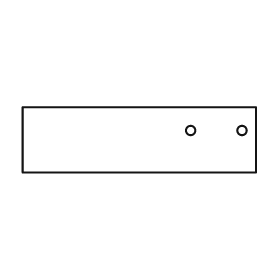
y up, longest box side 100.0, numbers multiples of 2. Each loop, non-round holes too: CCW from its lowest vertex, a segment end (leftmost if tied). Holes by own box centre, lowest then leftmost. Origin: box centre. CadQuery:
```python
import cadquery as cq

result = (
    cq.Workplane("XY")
    .moveTo(-50.0, -14.0)
    .lineTo(50.0, -14.0)
    .lineTo(50.0, 14.0)
    .lineTo(-50.0, 14.0)
    .close()
    .moveTo(22.0, 4.0)
    .circle(2.0)
    .moveTo(44.0, 4.0)
    .circle(2.0)
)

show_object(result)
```